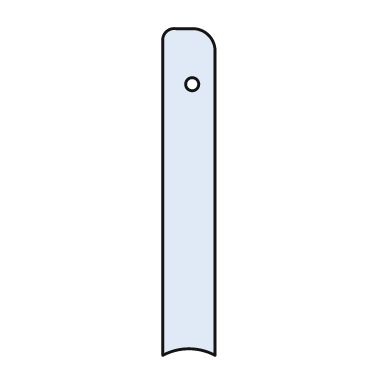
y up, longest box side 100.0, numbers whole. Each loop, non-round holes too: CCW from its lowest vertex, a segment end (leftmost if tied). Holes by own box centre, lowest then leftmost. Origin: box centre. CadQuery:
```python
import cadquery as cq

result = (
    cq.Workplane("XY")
    .moveTo(-8.0, -50.0)
    .threePointArc((0.0, -48.0), (8.0, -50.0))
    .lineTo(8.0, 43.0)
    .threePointArc((6.0, 48.0), (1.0, 50.0))
    .lineTo(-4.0, 50.0)
    .threePointArc((-7.0, 49.0), (-8.0, 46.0))
    .close()
    .moveTo(1.0, 33.0)
    .circle(2.0)
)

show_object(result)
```